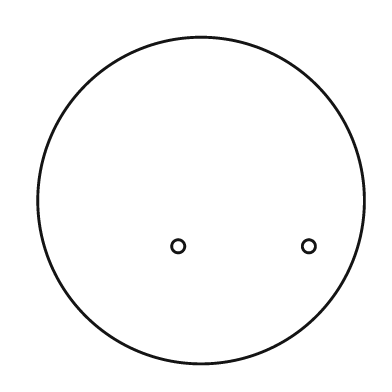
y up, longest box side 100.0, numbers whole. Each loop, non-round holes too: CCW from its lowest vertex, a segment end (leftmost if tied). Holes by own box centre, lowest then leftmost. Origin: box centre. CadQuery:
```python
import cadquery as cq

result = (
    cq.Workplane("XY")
    .moveTo(0.0, 0.0)
    .circle(50.0)
    .moveTo(-7.0, -14.0)
    .circle(2.0)
    .moveTo(33.0, -14.0)
    .circle(2.0)
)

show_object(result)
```